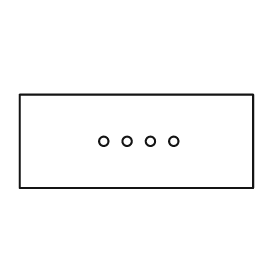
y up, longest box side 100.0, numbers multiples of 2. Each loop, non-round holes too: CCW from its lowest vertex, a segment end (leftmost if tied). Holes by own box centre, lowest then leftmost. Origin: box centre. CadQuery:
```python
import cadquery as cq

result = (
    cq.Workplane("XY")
    .moveTo(-50.0, -20.0)
    .lineTo(50.0, -20.0)
    .lineTo(50.0, 20.0)
    .lineTo(-50.0, 20.0)
    .close()
    .moveTo(-14.0, 0.0)
    .circle(2.0)
    .moveTo(-4.0, 0.0)
    .circle(2.0)
    .moveTo(6.0, 0.0)
    .circle(2.0)
    .moveTo(16.0, 0.0)
    .circle(2.0)
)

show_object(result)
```